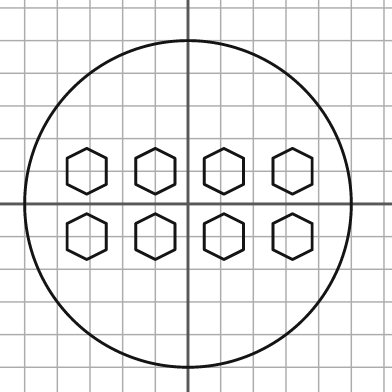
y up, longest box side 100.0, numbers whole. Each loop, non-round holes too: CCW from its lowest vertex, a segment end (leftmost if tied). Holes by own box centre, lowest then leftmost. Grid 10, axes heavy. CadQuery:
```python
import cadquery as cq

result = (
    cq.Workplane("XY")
    .moveTo(0.0, 0.0)
    .circle(50.0)
    .moveTo(-31.0, -17.0)
    .lineTo(-25.0, -14.0)
    .lineTo(-25.0, -6.0)
    .lineTo(-31.0, -3.0)
    .lineTo(-37.0, -6.0)
    .lineTo(-37.0, -14.0)
    .close()
    .moveTo(-10.0, -17.0)
    .lineTo(-4.0, -14.0)
    .lineTo(-4.0, -6.0)
    .lineTo(-10.0, -3.0)
    .lineTo(-16.0, -6.0)
    .lineTo(-16.0, -14.0)
    .close()
    .moveTo(11.0, -17.0)
    .lineTo(17.0, -14.0)
    .lineTo(17.0, -6.0)
    .lineTo(11.0, -3.0)
    .lineTo(5.0, -6.0)
    .lineTo(5.0, -14.0)
    .close()
    .moveTo(32.0, -17.0)
    .lineTo(38.0, -14.0)
    .lineTo(38.0, -6.0)
    .lineTo(32.0, -3.0)
    .lineTo(26.0, -6.0)
    .lineTo(26.0, -14.0)
    .close()
    .moveTo(-31.0, 3.0)
    .lineTo(-25.0, 6.0)
    .lineTo(-25.0, 14.0)
    .lineTo(-31.0, 17.0)
    .lineTo(-37.0, 14.0)
    .lineTo(-37.0, 6.0)
    .close()
    .moveTo(-10.0, 3.0)
    .lineTo(-4.0, 6.0)
    .lineTo(-4.0, 14.0)
    .lineTo(-10.0, 17.0)
    .lineTo(-16.0, 14.0)
    .lineTo(-16.0, 6.0)
    .close()
    .moveTo(11.0, 3.0)
    .lineTo(17.0, 6.0)
    .lineTo(17.0, 14.0)
    .lineTo(11.0, 17.0)
    .lineTo(5.0, 14.0)
    .lineTo(5.0, 6.0)
    .close()
    .moveTo(32.0, 3.0)
    .lineTo(38.0, 6.0)
    .lineTo(38.0, 14.0)
    .lineTo(32.0, 17.0)
    .lineTo(26.0, 14.0)
    .lineTo(26.0, 6.0)
    .close()
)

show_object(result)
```